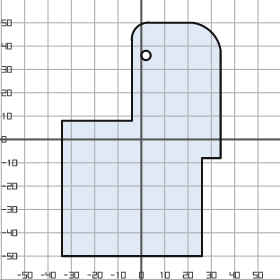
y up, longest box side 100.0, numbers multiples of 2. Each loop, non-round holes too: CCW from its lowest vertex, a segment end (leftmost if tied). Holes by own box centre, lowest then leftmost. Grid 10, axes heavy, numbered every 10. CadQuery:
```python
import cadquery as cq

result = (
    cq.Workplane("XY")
    .moveTo(-34.0, -50.0)
    .lineTo(26.0, -50.0)
    .lineTo(26.0, -8.0)
    .lineTo(34.0, -8.0)
    .lineTo(34.0, 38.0)
    .threePointArc((30.0, 46.0), (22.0, 50.0))
    .lineTo(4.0, 50.0)
    .threePointArc((-2.0, 48.0), (-4.0, 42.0))
    .lineTo(-4.0, 8.0)
    .lineTo(-34.0, 8.0)
    .close()
    .moveTo(2.0, 36.0)
    .circle(2.0)
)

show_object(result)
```